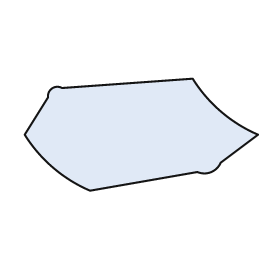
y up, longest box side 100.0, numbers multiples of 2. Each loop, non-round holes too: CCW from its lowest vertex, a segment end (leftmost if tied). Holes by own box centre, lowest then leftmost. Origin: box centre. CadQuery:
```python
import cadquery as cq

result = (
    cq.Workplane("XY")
    .moveTo(-22.0, -24.0)
    .lineTo(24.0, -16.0)
    .threePointArc((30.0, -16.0), (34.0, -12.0))
    .lineTo(50.0, 0.0)
    .threePointArc((34.0, 10.0), (22.0, 24.0))
    .lineTo(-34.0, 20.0)
    .threePointArc((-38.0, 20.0), (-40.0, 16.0))
    .lineTo(-50.0, 0.0)
    .threePointArc((-38.0, -14.0), (-22.0, -24.0))
    .close()
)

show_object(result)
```